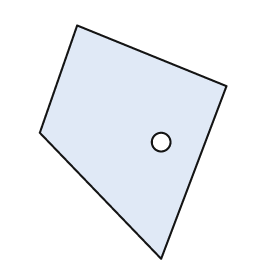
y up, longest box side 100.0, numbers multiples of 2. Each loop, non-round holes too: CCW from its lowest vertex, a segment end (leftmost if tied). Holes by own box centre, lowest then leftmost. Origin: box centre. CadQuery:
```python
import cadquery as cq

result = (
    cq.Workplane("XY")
    .moveTo(12.0, -50.0)
    .lineTo(40.0, 24.0)
    .lineTo(-24.0, 50.0)
    .lineTo(-40.0, 4.0)
    .close()
    .moveTo(12.0, 0.0)
    .circle(4.0)
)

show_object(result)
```